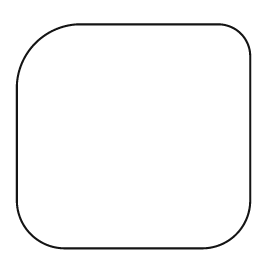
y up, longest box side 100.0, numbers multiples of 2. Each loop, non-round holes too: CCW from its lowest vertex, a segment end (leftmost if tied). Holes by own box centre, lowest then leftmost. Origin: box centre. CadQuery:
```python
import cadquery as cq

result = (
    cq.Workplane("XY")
    .moveTo(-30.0, -48.0)
    .lineTo(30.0, -48.0)
    .threePointArc((44.0, -42.0), (50.0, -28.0))
    .lineTo(50.0, 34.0)
    .threePointArc((46.0, 44.0), (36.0, 48.0))
    .lineTo(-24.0, 48.0)
    .threePointArc((-42.0, 40.0), (-50.0, 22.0))
    .lineTo(-50.0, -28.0)
    .threePointArc((-44.0, -42.0), (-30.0, -48.0))
    .close()
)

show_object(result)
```